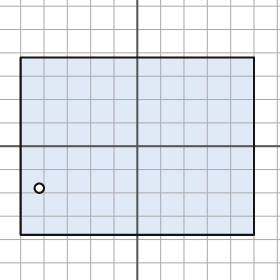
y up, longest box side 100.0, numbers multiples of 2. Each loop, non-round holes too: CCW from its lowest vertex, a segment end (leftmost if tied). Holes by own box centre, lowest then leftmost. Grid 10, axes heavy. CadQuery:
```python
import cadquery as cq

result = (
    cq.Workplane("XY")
    .moveTo(-50.0, -38.0)
    .lineTo(50.0, -38.0)
    .lineTo(50.0, 38.0)
    .lineTo(-50.0, 38.0)
    .close()
    .moveTo(-42.0, -18.0)
    .circle(2.0)
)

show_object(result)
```